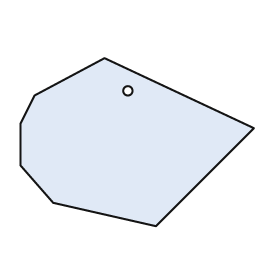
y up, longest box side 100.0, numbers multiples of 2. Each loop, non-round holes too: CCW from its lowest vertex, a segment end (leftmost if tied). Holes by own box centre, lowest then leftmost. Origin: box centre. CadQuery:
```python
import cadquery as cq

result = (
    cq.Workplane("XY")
    .moveTo(8.0, -36.0)
    .lineTo(50.0, 6.0)
    .lineTo(-14.0, 36.0)
    .lineTo(-44.0, 20.0)
    .lineTo(-50.0, 8.0)
    .lineTo(-50.0, -10.0)
    .lineTo(-36.0, -26.0)
    .close()
    .moveTo(-4.0, 22.0)
    .circle(2.0)
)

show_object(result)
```